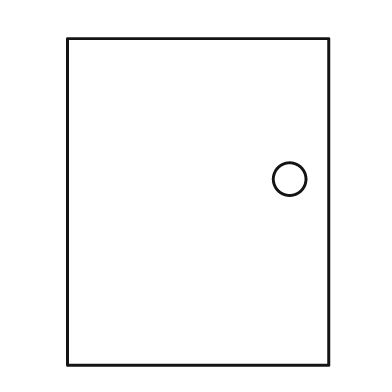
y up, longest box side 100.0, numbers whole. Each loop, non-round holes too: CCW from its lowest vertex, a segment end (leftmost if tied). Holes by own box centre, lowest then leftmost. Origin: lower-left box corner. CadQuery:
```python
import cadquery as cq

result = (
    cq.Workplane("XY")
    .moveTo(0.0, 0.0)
    .lineTo(80.0, 0.0)
    .lineTo(80.0, 100.0)
    .lineTo(0.0, 100.0)
    .close()
    .moveTo(68.0, 57.0)
    .circle(5.0)
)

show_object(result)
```